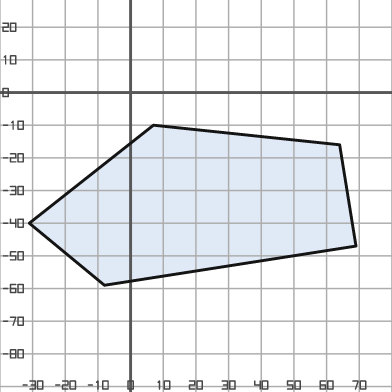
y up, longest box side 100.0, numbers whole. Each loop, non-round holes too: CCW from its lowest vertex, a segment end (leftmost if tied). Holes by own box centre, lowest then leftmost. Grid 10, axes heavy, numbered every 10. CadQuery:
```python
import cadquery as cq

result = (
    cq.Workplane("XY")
    .moveTo(-8.0, -59.0)
    .lineTo(69.0, -47.0)
    .lineTo(64.0, -16.0)
    .lineTo(7.0, -10.0)
    .lineTo(-31.0, -40.0)
    .close()
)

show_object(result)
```